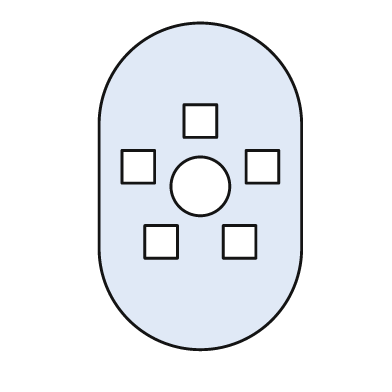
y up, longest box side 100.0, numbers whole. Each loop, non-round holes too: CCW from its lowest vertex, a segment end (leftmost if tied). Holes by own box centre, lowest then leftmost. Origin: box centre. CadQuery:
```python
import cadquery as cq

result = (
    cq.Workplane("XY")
    .moveTo(-31.0, -19.0)
    .threePointArc((0.0, -50.0), (31.0, -19.0))
    .lineTo(31.0, 19.0)
    .threePointArc((0.0, 50.0), (-31.0, 19.0))
    .close()
    .moveTo(-17.0, -22.0)
    .lineTo(-7.0, -22.0)
    .lineTo(-7.0, -12.0)
    .lineTo(-17.0, -12.0)
    .close()
    .moveTo(7.0, -22.0)
    .lineTo(17.0, -22.0)
    .lineTo(17.0, -12.0)
    .lineTo(7.0, -12.0)
    .close()
    .moveTo(0.0, 0.0)
    .circle(9.0)
    .moveTo(-24.0, 1.0)
    .lineTo(-14.0, 1.0)
    .lineTo(-14.0, 11.0)
    .lineTo(-24.0, 11.0)
    .close()
    .moveTo(14.0, 1.0)
    .lineTo(24.0, 1.0)
    .lineTo(24.0, 11.0)
    .lineTo(14.0, 11.0)
    .close()
    .moveTo(-5.0, 15.0)
    .lineTo(5.0, 15.0)
    .lineTo(5.0, 25.0)
    .lineTo(-5.0, 25.0)
    .close()
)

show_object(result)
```